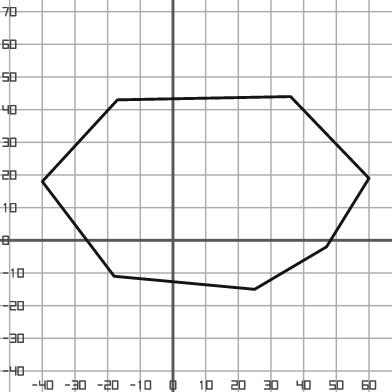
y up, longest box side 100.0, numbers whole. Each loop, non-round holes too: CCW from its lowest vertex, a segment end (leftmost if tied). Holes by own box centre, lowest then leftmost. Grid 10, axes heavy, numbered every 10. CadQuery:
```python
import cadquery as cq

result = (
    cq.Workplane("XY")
    .moveTo(25.0, -15.0)
    .lineTo(47.0, -2.0)
    .lineTo(60.0, 19.0)
    .lineTo(36.0, 44.0)
    .lineTo(-17.0, 43.0)
    .lineTo(-40.0, 18.0)
    .lineTo(-18.0, -11.0)
    .close()
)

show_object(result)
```